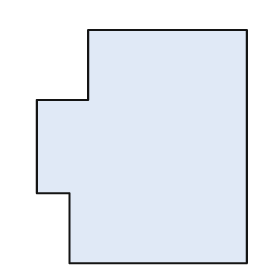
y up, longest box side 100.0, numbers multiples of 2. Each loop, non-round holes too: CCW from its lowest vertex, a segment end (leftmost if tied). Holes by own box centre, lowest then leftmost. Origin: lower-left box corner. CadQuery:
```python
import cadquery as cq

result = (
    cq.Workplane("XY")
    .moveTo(14.0, 0.0)
    .lineTo(90.0, 0.0)
    .lineTo(90.0, 100.0)
    .lineTo(22.0, 100.0)
    .lineTo(22.0, 70.0)
    .lineTo(0.0, 70.0)
    .lineTo(0.0, 30.0)
    .lineTo(14.0, 30.0)
    .close()
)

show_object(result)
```